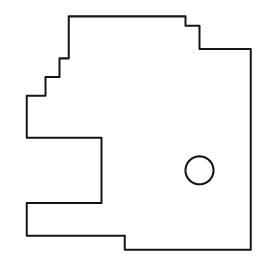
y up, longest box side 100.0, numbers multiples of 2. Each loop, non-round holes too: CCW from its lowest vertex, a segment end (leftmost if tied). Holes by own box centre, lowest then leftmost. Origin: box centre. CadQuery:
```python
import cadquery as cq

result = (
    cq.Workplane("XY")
    .moveTo(-6.0, -50.0)
    .lineTo(48.0, -50.0)
    .lineTo(48.0, 36.0)
    .lineTo(26.0, 36.0)
    .lineTo(26.0, 46.0)
    .lineTo(20.0, 46.0)
    .lineTo(20.0, 50.0)
    .lineTo(-30.0, 50.0)
    .lineTo(-30.0, 32.0)
    .lineTo(-34.0, 32.0)
    .lineTo(-34.0, 24.0)
    .lineTo(-40.0, 24.0)
    .lineTo(-40.0, 16.0)
    .lineTo(-48.0, 16.0)
    .lineTo(-48.0, -2.0)
    .lineTo(-16.0, -2.0)
    .lineTo(-16.0, -30.0)
    .lineTo(-48.0, -30.0)
    .lineTo(-48.0, -44.0)
    .lineTo(-6.0, -44.0)
    .close()
    .moveTo(26.0, -16.0)
    .circle(6.0)
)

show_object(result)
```